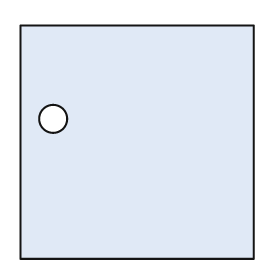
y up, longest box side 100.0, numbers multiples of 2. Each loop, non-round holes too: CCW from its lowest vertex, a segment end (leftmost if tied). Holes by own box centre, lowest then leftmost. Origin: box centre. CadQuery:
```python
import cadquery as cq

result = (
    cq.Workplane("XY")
    .moveTo(-50.0, -50.0)
    .lineTo(50.0, -50.0)
    .lineTo(50.0, 50.0)
    .lineTo(-50.0, 50.0)
    .close()
    .moveTo(-36.0, 10.0)
    .circle(6.0)
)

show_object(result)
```